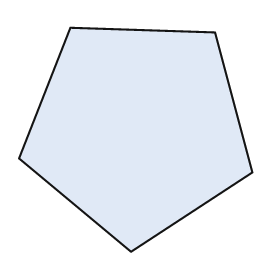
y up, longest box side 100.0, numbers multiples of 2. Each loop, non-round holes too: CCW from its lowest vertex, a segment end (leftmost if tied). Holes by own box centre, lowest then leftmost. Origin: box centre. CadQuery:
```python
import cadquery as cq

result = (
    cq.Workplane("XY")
    .moveTo(-2.0, -48.0)
    .lineTo(50.0, -14.0)
    .lineTo(34.0, 46.0)
    .lineTo(-28.0, 48.0)
    .lineTo(-50.0, -8.0)
    .close()
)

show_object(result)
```